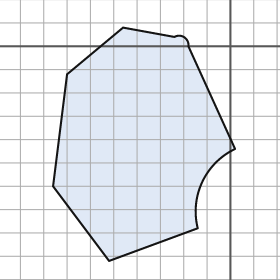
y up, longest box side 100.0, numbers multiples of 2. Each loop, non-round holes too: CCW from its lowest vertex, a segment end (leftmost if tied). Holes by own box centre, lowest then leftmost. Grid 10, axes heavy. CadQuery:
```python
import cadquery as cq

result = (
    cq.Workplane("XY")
    .moveTo(-52.0, -92.0)
    .lineTo(-14.0, -78.0)
    .threePointArc((-12.0, -58.0), (2.0, -44.0))
    .lineTo(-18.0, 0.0)
    .threePointArc((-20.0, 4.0), (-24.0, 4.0))
    .lineTo(-46.0, 8.0)
    .lineTo(-70.0, -12.0)
    .lineTo(-76.0, -60.0)
    .close()
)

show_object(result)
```